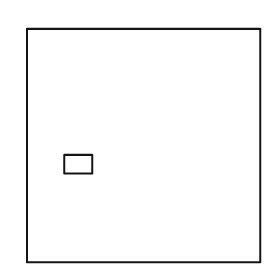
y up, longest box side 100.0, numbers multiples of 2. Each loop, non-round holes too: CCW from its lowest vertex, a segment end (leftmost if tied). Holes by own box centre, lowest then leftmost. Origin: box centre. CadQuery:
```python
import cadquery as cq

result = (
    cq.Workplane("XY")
    .moveTo(-50.0, -50.0)
    .lineTo(50.0, -50.0)
    .lineTo(50.0, 50.0)
    .lineTo(-50.0, 50.0)
    .close()
    .moveTo(-34.0, -12.0)
    .lineTo(-22.0, -12.0)
    .lineTo(-22.0, -4.0)
    .lineTo(-34.0, -4.0)
    .close()
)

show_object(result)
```